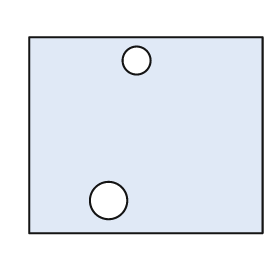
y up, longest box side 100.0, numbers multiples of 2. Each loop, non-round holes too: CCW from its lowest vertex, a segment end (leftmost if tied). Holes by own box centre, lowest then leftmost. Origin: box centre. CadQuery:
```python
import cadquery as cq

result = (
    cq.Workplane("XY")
    .moveTo(-50.0, -42.0)
    .lineTo(50.0, -42.0)
    .lineTo(50.0, 42.0)
    .lineTo(-50.0, 42.0)
    .close()
    .moveTo(-16.0, -28.0)
    .circle(8.0)
    .moveTo(-4.0, 32.0)
    .circle(6.0)
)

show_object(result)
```